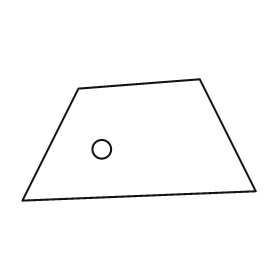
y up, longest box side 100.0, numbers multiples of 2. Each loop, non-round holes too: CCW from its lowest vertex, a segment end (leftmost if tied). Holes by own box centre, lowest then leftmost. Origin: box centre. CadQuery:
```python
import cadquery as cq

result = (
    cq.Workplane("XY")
    .moveTo(-50.0, -26.0)
    .lineTo(50.0, -22.0)
    .lineTo(26.0, 26.0)
    .lineTo(-26.0, 22.0)
    .close()
    .moveTo(-16.0, -4.0)
    .circle(4.0)
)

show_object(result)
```